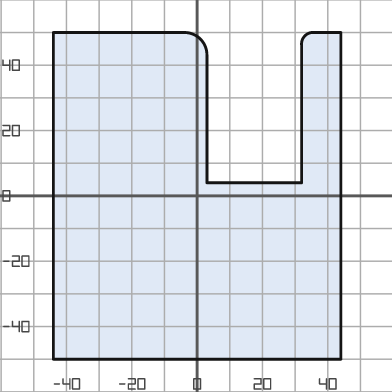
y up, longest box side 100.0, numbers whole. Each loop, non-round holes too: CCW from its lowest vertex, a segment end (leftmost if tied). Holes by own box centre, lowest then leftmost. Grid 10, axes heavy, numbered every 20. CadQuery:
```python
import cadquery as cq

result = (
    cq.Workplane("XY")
    .moveTo(-44.0, -50.0)
    .lineTo(44.0, -50.0)
    .lineTo(44.0, 50.0)
    .lineTo(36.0, 50.0)
    .threePointArc((33.0, 49.0), (32.0, 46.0))
    .lineTo(32.0, 4.0)
    .lineTo(3.0, 4.0)
    .lineTo(3.0, 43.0)
    .threePointArc((1.0, 48.0), (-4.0, 50.0))
    .lineTo(-44.0, 50.0)
    .close()
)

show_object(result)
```